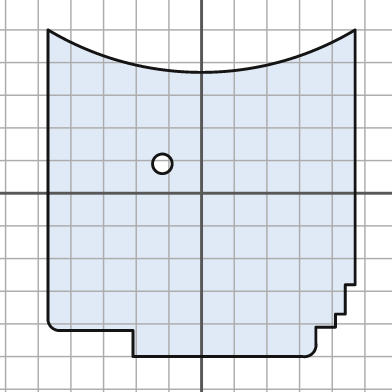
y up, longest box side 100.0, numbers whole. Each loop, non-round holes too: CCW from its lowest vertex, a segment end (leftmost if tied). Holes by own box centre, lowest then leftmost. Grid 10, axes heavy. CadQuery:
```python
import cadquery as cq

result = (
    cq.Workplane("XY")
    .moveTo(-21.0, -50.0)
    .lineTo(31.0, -50.0)
    .threePointArc((34.0, -49.0), (35.0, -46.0))
    .lineTo(35.0, -41.0)
    .lineTo(41.0, -41.0)
    .lineTo(41.0, -37.0)
    .lineTo(44.0, -37.0)
    .lineTo(44.0, -28.0)
    .lineTo(47.0, -28.0)
    .lineTo(47.0, 50.0)
    .threePointArc((0.0, 37.0), (-47.0, 50.0))
    .lineTo(-47.0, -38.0)
    .threePointArc((-46.0, -41.0), (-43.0, -42.0))
    .lineTo(-21.0, -42.0)
    .close()
    .moveTo(-12.0, 9.0)
    .circle(3.0)
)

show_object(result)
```